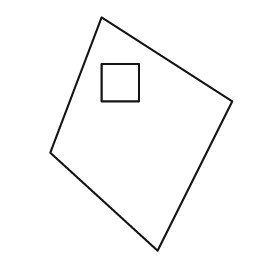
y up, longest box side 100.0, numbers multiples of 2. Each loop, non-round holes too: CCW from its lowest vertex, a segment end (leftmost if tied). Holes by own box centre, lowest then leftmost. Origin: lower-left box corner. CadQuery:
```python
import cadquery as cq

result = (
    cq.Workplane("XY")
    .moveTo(46.0, 0.0)
    .lineTo(78.0, 64.0)
    .lineTo(22.0, 100.0)
    .lineTo(0.0, 42.0)
    .close()
    .moveTo(22.0, 64.0)
    .lineTo(38.0, 64.0)
    .lineTo(38.0, 80.0)
    .lineTo(22.0, 80.0)
    .close()
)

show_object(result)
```